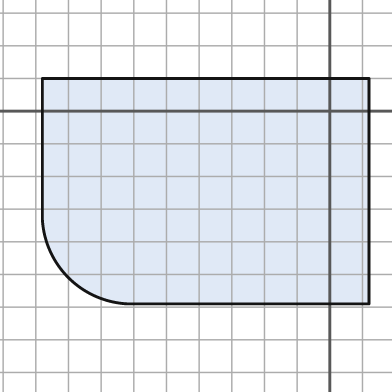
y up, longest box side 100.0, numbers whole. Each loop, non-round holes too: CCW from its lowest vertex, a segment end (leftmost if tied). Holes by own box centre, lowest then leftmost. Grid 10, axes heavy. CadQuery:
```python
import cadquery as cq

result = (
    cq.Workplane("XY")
    .moveTo(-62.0, -59.0)
    .lineTo(12.0, -59.0)
    .lineTo(12.0, 10.0)
    .lineTo(-88.0, 10.0)
    .lineTo(-88.0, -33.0)
    .threePointArc((-80.0, -51.0), (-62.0, -59.0))
    .close()
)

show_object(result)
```